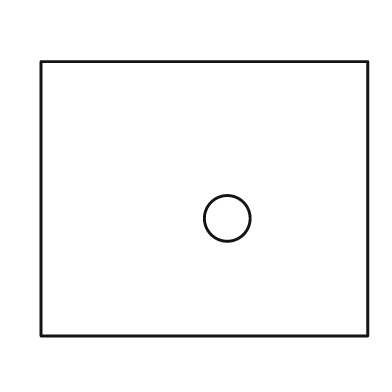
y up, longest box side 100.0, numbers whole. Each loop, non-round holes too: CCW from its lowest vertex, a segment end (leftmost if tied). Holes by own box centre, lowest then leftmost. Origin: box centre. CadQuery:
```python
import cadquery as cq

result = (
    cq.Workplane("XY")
    .moveTo(-50.0, -42.0)
    .lineTo(50.0, -42.0)
    .lineTo(50.0, 42.0)
    .lineTo(-50.0, 42.0)
    .close()
    .moveTo(7.0, -6.0)
    .circle(7.0)
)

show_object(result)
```